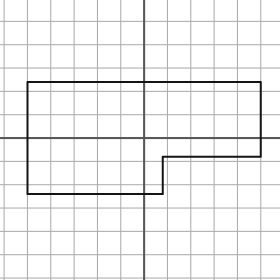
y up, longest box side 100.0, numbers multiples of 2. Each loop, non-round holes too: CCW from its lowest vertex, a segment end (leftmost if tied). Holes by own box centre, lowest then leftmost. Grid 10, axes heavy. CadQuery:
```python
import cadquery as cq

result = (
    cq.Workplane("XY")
    .moveTo(-50.0, -24.0)
    .lineTo(8.0, -24.0)
    .lineTo(8.0, -8.0)
    .lineTo(50.0, -8.0)
    .lineTo(50.0, 24.0)
    .lineTo(-50.0, 24.0)
    .close()
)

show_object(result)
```